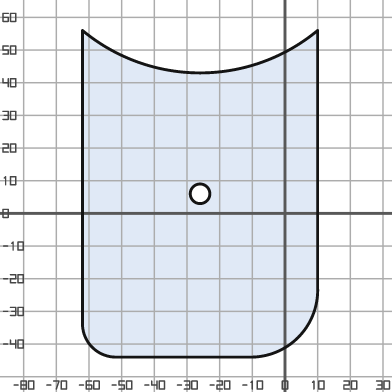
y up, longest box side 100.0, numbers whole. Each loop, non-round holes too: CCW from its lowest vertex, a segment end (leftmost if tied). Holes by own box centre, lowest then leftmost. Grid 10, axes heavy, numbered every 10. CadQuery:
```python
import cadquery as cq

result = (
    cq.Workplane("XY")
    .moveTo(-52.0, -44.0)
    .lineTo(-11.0, -44.0)
    .threePointArc((4.0, -38.0), (10.0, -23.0))
    .lineTo(10.0, 56.0)
    .threePointArc((-26.0, 43.0), (-62.0, 56.0))
    .lineTo(-62.0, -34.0)
    .threePointArc((-59.0, -41.0), (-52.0, -44.0))
    .close()
    .moveTo(-26.0, 6.0)
    .circle(3.0)
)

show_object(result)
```